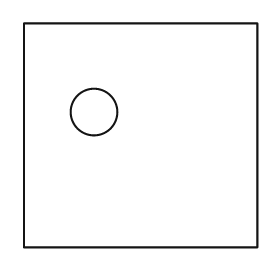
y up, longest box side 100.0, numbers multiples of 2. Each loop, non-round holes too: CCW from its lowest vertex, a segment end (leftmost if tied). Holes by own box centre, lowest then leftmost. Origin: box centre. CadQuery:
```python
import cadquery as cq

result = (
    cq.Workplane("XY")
    .moveTo(-50.0, -48.0)
    .lineTo(50.0, -48.0)
    .lineTo(50.0, 48.0)
    .lineTo(-50.0, 48.0)
    .close()
    .moveTo(-20.0, 10.0)
    .circle(10.0)
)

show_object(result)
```